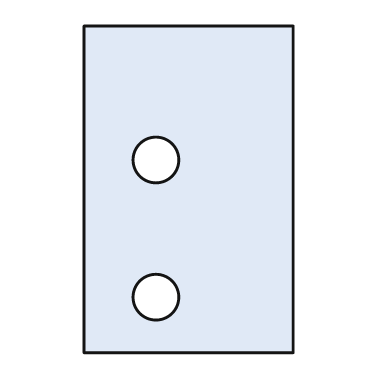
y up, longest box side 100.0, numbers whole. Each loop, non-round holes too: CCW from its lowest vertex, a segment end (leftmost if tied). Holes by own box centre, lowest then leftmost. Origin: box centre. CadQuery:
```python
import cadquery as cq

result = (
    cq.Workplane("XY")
    .moveTo(-32.0, -50.0)
    .lineTo(32.0, -50.0)
    .lineTo(32.0, 50.0)
    .lineTo(-32.0, 50.0)
    .close()
    .moveTo(-10.0, -33.0)
    .circle(7.0)
    .moveTo(-10.0, 9.0)
    .circle(7.0)
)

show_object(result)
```